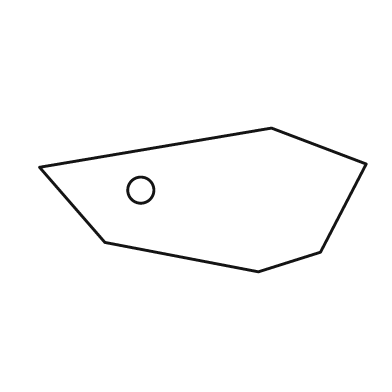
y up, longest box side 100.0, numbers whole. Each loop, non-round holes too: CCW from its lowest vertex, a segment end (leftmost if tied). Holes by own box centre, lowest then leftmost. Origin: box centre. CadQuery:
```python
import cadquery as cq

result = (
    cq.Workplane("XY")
    .moveTo(17.0, -22.0)
    .lineTo(36.0, -16.0)
    .lineTo(50.0, 11.0)
    .lineTo(21.0, 22.0)
    .lineTo(-50.0, 10.0)
    .lineTo(-30.0, -13.0)
    .close()
    .moveTo(-19.0, 3.0)
    .circle(4.0)
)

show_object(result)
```